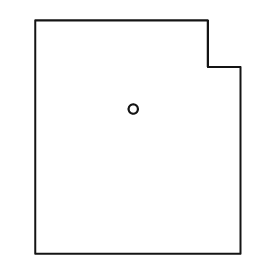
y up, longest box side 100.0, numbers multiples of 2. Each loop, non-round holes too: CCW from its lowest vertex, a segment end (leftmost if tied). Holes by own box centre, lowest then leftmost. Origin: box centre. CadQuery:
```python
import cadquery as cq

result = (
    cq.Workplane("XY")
    .moveTo(-44.0, -50.0)
    .lineTo(44.0, -50.0)
    .lineTo(44.0, 30.0)
    .lineTo(30.0, 30.0)
    .lineTo(30.0, 50.0)
    .lineTo(-44.0, 50.0)
    .close()
    .moveTo(-2.0, 12.0)
    .circle(2.0)
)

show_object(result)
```